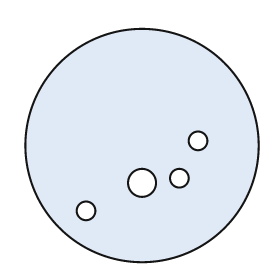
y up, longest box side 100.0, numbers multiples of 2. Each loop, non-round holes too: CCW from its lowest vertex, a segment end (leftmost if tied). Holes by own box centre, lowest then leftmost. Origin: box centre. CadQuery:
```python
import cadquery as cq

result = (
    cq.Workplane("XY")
    .moveTo(0.0, 0.0)
    .circle(50.0)
    .moveTo(-24.0, -28.0)
    .circle(4.0)
    .moveTo(0.0, -16.0)
    .circle(6.0)
    .moveTo(16.0, -14.0)
    .circle(4.0)
    .moveTo(24.0, 2.0)
    .circle(4.0)
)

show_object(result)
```